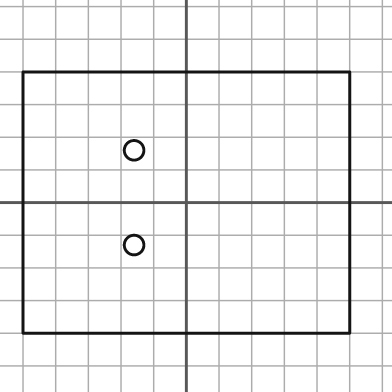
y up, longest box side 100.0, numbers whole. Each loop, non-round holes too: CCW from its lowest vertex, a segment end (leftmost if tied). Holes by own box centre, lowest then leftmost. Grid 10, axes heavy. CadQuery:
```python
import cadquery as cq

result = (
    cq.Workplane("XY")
    .moveTo(-50.0, -40.0)
    .lineTo(50.0, -40.0)
    .lineTo(50.0, 40.0)
    .lineTo(-50.0, 40.0)
    .close()
    .moveTo(-16.0, -13.0)
    .circle(3.0)
    .moveTo(-16.0, 16.0)
    .circle(3.0)
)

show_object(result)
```